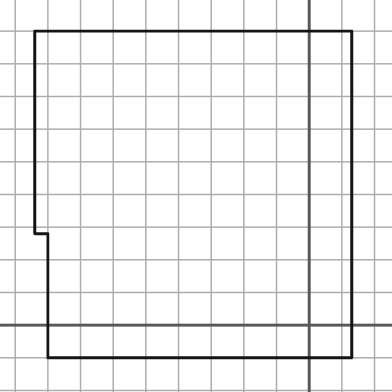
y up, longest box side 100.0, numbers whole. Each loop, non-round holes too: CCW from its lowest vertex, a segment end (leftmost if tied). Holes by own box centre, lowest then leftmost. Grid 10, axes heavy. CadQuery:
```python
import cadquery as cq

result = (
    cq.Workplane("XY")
    .moveTo(-80.0, -10.0)
    .lineTo(13.0, -10.0)
    .lineTo(13.0, 90.0)
    .lineTo(-84.0, 90.0)
    .lineTo(-84.0, 28.0)
    .lineTo(-80.0, 28.0)
    .close()
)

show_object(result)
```